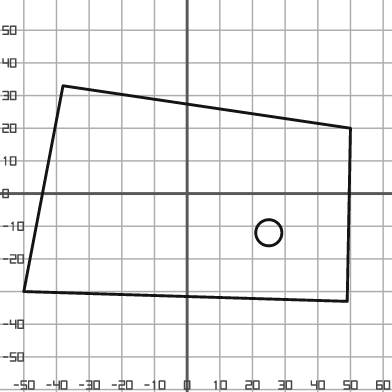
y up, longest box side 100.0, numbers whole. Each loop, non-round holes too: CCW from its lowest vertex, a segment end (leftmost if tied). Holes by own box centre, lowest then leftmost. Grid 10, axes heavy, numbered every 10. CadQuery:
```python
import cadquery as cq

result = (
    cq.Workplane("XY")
    .moveTo(49.0, -33.0)
    .lineTo(50.0, 20.0)
    .lineTo(-38.0, 33.0)
    .lineTo(-50.0, -30.0)
    .close()
    .moveTo(25.0, -12.0)
    .circle(4.0)
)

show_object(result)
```